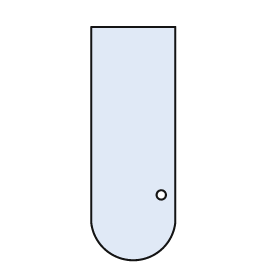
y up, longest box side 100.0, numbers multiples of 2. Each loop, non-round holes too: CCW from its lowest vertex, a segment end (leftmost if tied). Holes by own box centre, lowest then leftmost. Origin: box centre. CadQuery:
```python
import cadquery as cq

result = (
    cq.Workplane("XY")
    .moveTo(-18.0, -34.0)
    .threePointArc((0.0, -50.0), (18.0, -34.0))
    .lineTo(18.0, 50.0)
    .lineTo(-18.0, 50.0)
    .close()
    .moveTo(12.0, -22.0)
    .circle(2.0)
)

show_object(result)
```